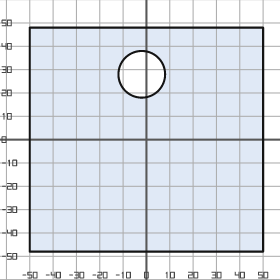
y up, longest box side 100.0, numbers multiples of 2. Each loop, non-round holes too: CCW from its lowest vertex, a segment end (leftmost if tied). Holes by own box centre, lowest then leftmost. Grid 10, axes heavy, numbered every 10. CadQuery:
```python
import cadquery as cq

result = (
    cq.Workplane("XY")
    .moveTo(-50.0, -48.0)
    .lineTo(50.0, -48.0)
    .lineTo(50.0, 48.0)
    .lineTo(-50.0, 48.0)
    .close()
    .moveTo(-2.0, 28.0)
    .circle(10.0)
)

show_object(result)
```